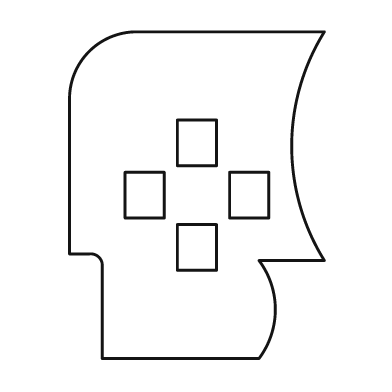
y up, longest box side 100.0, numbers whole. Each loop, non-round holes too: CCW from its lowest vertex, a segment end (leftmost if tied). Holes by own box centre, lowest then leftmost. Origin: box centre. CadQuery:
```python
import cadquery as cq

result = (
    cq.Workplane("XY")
    .moveTo(-29.0, -50.0)
    .lineTo(19.0, -50.0)
    .threePointArc((24.0, -35.0), (19.0, -20.0))
    .lineTo(39.0, -20.0)
    .threePointArc((29.0, 15.0), (39.0, 50.0))
    .lineTo(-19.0, 50.0)
    .threePointArc((-33.0, 44.0), (-39.0, 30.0))
    .lineTo(-39.0, -18.0)
    .lineTo(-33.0, -18.0)
    .threePointArc((-30.0, -19.0), (-29.0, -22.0))
    .close()
    .moveTo(-6.0, -23.0)
    .lineTo(6.0, -23.0)
    .lineTo(6.0, -9.0)
    .lineTo(-6.0, -9.0)
    .close()
    .moveTo(-22.0, -7.0)
    .lineTo(-10.0, -7.0)
    .lineTo(-10.0, 7.0)
    .lineTo(-22.0, 7.0)
    .close()
    .moveTo(10.0, -7.0)
    .lineTo(22.0, -7.0)
    .lineTo(22.0, 7.0)
    .lineTo(10.0, 7.0)
    .close()
    .moveTo(-6.0, 9.0)
    .lineTo(6.0, 9.0)
    .lineTo(6.0, 23.0)
    .lineTo(-6.0, 23.0)
    .close()
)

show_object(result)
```